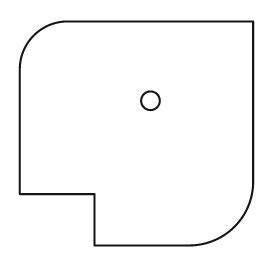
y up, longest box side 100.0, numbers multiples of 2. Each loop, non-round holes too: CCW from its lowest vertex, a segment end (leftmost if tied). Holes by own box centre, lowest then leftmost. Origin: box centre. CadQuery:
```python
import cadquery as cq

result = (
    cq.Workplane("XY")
    .moveTo(-18.0, -48.0)
    .lineTo(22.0, -48.0)
    .threePointArc((42.0, -40.0), (50.0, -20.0))
    .lineTo(50.0, 48.0)
    .lineTo(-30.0, 48.0)
    .threePointArc((-44.0, 42.0), (-50.0, 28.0))
    .lineTo(-50.0, -26.0)
    .lineTo(-18.0, -26.0)
    .close()
    .moveTo(6.0, 14.0)
    .circle(4.0)
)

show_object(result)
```